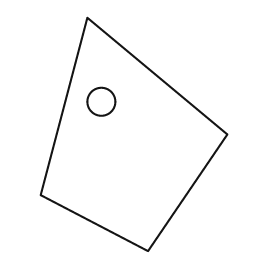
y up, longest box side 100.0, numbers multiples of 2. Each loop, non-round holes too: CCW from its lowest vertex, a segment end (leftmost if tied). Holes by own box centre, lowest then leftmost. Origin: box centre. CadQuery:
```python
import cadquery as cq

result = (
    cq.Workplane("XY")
    .moveTo(6.0, -50.0)
    .lineTo(40.0, 0.0)
    .lineTo(-20.0, 50.0)
    .lineTo(-40.0, -26.0)
    .close()
    .moveTo(-14.0, 14.0)
    .circle(6.0)
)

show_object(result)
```